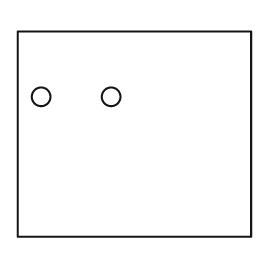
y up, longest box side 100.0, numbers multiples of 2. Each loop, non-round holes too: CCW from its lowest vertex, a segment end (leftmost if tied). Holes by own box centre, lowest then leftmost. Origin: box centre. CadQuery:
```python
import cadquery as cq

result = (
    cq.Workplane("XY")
    .moveTo(-50.0, -44.0)
    .lineTo(50.0, -44.0)
    .lineTo(50.0, 44.0)
    .lineTo(-50.0, 44.0)
    .close()
    .moveTo(-40.0, 16.0)
    .circle(4.0)
    .moveTo(-10.0, 16.0)
    .circle(4.0)
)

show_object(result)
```